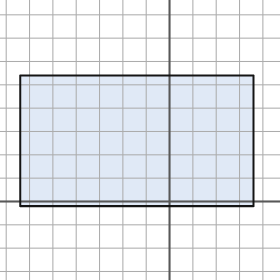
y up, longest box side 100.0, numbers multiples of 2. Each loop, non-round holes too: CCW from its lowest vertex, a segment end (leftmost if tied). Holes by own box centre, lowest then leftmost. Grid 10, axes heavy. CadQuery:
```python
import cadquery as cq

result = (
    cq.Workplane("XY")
    .moveTo(-64.0, -2.0)
    .lineTo(36.0, -2.0)
    .lineTo(36.0, 54.0)
    .lineTo(-64.0, 54.0)
    .close()
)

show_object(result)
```